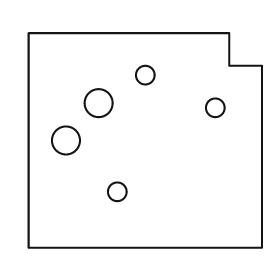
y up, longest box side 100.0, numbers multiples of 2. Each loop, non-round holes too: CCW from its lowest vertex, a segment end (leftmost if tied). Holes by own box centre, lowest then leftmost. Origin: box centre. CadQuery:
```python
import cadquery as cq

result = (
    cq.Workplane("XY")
    .moveTo(-50.0, -46.0)
    .lineTo(50.0, -46.0)
    .lineTo(50.0, 32.0)
    .lineTo(36.0, 32.0)
    .lineTo(36.0, 46.0)
    .lineTo(-50.0, 46.0)
    .close()
    .moveTo(-12.0, -22.0)
    .circle(4.0)
    .moveTo(-34.0, 0.0)
    .circle(6.0)
    .moveTo(30.0, 14.0)
    .circle(4.0)
    .moveTo(-20.0, 16.0)
    .circle(6.0)
    .moveTo(0.0, 28.0)
    .circle(4.0)
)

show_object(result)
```